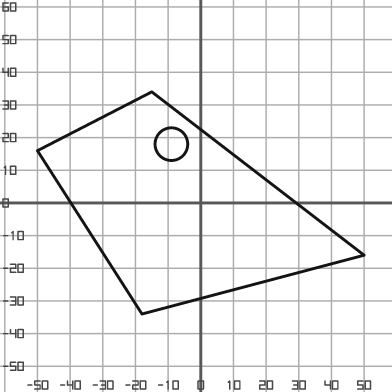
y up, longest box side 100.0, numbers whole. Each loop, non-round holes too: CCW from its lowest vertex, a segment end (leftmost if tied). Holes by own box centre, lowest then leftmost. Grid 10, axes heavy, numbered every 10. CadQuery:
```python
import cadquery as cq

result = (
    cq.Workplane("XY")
    .moveTo(-18.0, -34.0)
    .lineTo(50.0, -16.0)
    .lineTo(-15.0, 34.0)
    .lineTo(-50.0, 16.0)
    .close()
    .moveTo(-9.0, 18.0)
    .circle(5.0)
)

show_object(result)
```